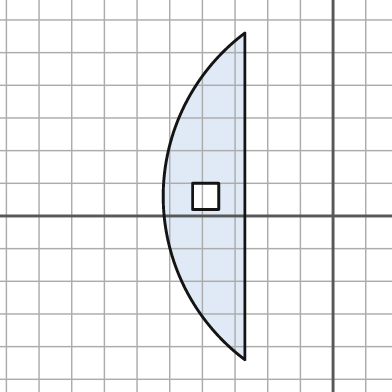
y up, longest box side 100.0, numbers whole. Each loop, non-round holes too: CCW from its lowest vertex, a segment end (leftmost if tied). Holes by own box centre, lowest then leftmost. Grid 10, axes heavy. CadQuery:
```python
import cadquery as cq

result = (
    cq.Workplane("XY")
    .moveTo(-27.0, -44.0)
    .lineTo(-27.0, 56.0)
    .threePointArc((-52.0, 6.0), (-27.0, -44.0))
    .close()
    .moveTo(-43.0, 2.0)
    .lineTo(-35.0, 2.0)
    .lineTo(-35.0, 10.0)
    .lineTo(-43.0, 10.0)
    .close()
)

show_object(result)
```